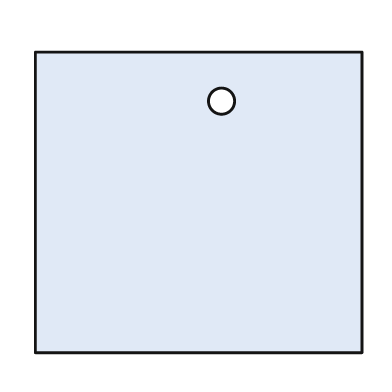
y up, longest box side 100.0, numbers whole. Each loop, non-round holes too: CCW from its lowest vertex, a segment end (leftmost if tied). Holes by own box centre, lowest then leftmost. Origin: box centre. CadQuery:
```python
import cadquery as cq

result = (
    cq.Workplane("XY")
    .moveTo(-50.0, -46.0)
    .lineTo(50.0, -46.0)
    .lineTo(50.0, 46.0)
    .lineTo(-50.0, 46.0)
    .close()
    .moveTo(7.0, 31.0)
    .circle(4.0)
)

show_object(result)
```